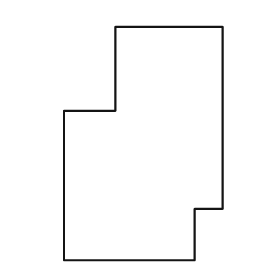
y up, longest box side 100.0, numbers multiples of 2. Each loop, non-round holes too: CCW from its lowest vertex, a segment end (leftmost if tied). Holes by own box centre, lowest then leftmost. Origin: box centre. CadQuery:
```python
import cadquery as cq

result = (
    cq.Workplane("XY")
    .moveTo(-34.0, -50.0)
    .lineTo(22.0, -50.0)
    .lineTo(22.0, -28.0)
    .lineTo(34.0, -28.0)
    .lineTo(34.0, 50.0)
    .lineTo(-12.0, 50.0)
    .lineTo(-12.0, 14.0)
    .lineTo(-34.0, 14.0)
    .close()
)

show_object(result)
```